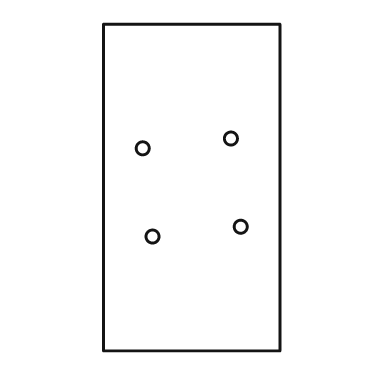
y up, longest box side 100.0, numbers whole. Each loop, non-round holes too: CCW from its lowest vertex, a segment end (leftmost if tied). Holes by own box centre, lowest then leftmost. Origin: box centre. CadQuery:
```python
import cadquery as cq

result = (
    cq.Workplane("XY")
    .moveTo(-27.0, -50.0)
    .lineTo(27.0, -50.0)
    .lineTo(27.0, 50.0)
    .lineTo(-27.0, 50.0)
    .close()
    .moveTo(-12.0, -15.0)
    .circle(2.0)
    .moveTo(15.0, -12.0)
    .circle(2.0)
    .moveTo(-15.0, 12.0)
    .circle(2.0)
    .moveTo(12.0, 15.0)
    .circle(2.0)
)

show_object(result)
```